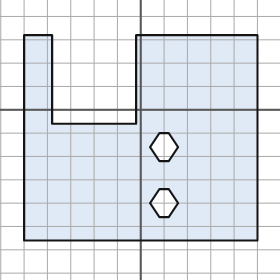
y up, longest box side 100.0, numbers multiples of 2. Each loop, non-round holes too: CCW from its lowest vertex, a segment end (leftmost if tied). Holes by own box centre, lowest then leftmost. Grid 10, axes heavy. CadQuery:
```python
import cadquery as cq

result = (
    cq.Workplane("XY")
    .moveTo(-50.0, -56.0)
    .lineTo(50.0, -56.0)
    .lineTo(50.0, 32.0)
    .lineTo(-2.0, 32.0)
    .lineTo(-2.0, -6.0)
    .lineTo(-38.0, -6.0)
    .lineTo(-38.0, 32.0)
    .lineTo(-50.0, 32.0)
    .close()
    .moveTo(8.0, -46.0)
    .lineTo(12.0, -46.0)
    .lineTo(16.0, -40.0)
    .lineTo(12.0, -34.0)
    .lineTo(8.0, -34.0)
    .lineTo(4.0, -40.0)
    .close()
    .moveTo(8.0, -22.0)
    .lineTo(12.0, -22.0)
    .lineTo(16.0, -16.0)
    .lineTo(12.0, -10.0)
    .lineTo(8.0, -10.0)
    .lineTo(4.0, -16.0)
    .close()
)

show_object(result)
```